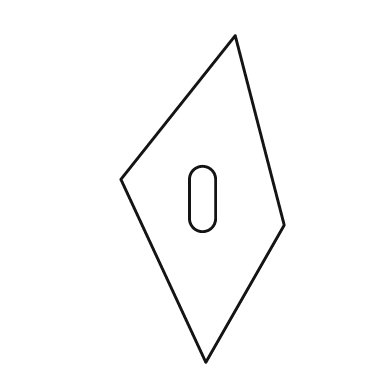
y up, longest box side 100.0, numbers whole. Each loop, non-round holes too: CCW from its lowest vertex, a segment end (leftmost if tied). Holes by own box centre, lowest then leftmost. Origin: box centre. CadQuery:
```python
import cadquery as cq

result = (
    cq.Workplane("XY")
    .moveTo(1.0, -50.0)
    .lineTo(25.0, -8.0)
    .lineTo(10.0, 50.0)
    .lineTo(-25.0, 6.0)
    .close()
    .moveTo(-4.0, -6.0)
    .threePointArc((0.0, -10.0), (4.0, -6.0))
    .lineTo(4.0, 6.0)
    .threePointArc((0.0, 10.0), (-4.0, 6.0))
    .close()
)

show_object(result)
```